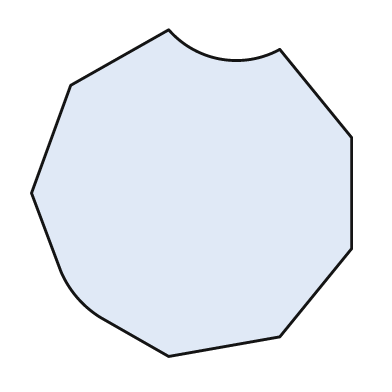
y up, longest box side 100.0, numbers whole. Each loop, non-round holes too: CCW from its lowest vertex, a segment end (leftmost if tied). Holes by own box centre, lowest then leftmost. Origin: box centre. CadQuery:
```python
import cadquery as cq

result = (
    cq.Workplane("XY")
    .moveTo(-7.0, -50.0)
    .lineTo(27.0, -44.0)
    .lineTo(49.0, -17.0)
    .lineTo(49.0, 17.0)
    .lineTo(27.0, 44.0)
    .threePointArc((9.0, 41.0), (-7.0, 50.0))
    .lineTo(-37.0, 33.0)
    .lineTo(-49.0, 0.0)
    .lineTo(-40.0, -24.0)
    .threePointArc((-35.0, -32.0), (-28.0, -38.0))
    .close()
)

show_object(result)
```